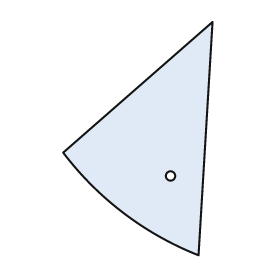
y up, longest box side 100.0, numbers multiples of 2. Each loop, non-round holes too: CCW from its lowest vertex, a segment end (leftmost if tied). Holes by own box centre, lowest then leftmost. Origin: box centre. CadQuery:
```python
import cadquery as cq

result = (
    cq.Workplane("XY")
    .moveTo(26.0, -50.0)
    .lineTo(32.0, 50.0)
    .lineTo(-32.0, -6.0)
    .threePointArc((-6.0, -32.0), (26.0, -50.0))
    .close()
    .moveTo(14.0, -16.0)
    .circle(2.0)
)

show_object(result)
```